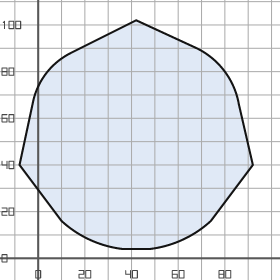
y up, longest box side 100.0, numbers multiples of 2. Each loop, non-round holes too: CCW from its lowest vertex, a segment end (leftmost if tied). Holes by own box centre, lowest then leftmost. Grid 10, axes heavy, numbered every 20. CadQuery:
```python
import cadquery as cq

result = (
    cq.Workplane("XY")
    .moveTo(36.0, 4.0)
    .lineTo(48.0, 4.0)
    .threePointArc((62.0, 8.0), (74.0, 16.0))
    .lineTo(92.0, 40.0)
    .lineTo(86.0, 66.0)
    .threePointArc((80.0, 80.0), (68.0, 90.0))
    .lineTo(42.0, 102.0)
    .lineTo(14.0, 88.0)
    .threePointArc((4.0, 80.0), (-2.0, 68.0))
    .lineTo(-8.0, 40.0)
    .lineTo(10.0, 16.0)
    .threePointArc((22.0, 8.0), (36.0, 4.0))
    .close()
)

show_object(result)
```